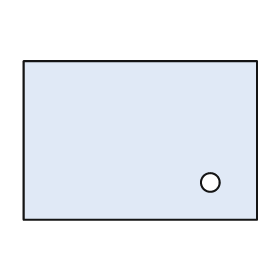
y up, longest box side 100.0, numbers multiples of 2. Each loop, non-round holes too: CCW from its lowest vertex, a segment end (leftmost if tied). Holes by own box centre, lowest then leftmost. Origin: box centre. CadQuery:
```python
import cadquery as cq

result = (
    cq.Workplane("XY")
    .moveTo(-50.0, -34.0)
    .lineTo(50.0, -34.0)
    .lineTo(50.0, 34.0)
    .lineTo(-50.0, 34.0)
    .close()
    .moveTo(30.0, -18.0)
    .circle(4.0)
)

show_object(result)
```